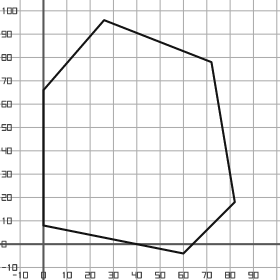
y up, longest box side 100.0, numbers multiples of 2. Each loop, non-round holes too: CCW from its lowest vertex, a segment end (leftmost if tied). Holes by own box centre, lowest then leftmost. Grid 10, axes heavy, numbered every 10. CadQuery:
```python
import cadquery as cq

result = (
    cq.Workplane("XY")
    .moveTo(60.0, -4.0)
    .lineTo(82.0, 18.0)
    .lineTo(72.0, 78.0)
    .lineTo(26.0, 96.0)
    .lineTo(0.0, 66.0)
    .lineTo(0.0, 8.0)
    .close()
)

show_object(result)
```